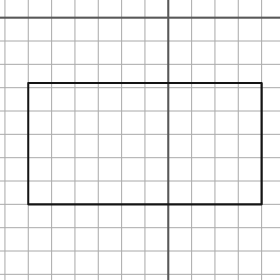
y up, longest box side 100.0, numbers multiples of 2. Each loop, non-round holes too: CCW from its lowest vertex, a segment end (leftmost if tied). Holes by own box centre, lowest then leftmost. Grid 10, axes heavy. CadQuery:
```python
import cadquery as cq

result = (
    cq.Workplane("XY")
    .moveTo(-60.0, -80.0)
    .lineTo(40.0, -80.0)
    .lineTo(40.0, -28.0)
    .lineTo(-60.0, -28.0)
    .close()
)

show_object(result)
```